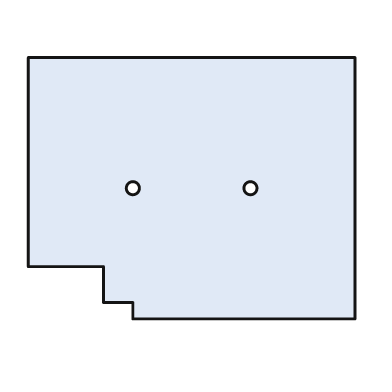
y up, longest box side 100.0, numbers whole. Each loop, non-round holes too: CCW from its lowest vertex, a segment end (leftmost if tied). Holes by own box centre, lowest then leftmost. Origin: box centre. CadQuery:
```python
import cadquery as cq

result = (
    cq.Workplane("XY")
    .moveTo(-18.0, -40.0)
    .lineTo(50.0, -40.0)
    .lineTo(50.0, 40.0)
    .lineTo(-50.0, 40.0)
    .lineTo(-50.0, -24.0)
    .lineTo(-27.0, -24.0)
    .lineTo(-27.0, -35.0)
    .lineTo(-18.0, -35.0)
    .close()
    .moveTo(-18.0, 0.0)
    .circle(2.0)
    .moveTo(18.0, 0.0)
    .circle(2.0)
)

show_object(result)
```